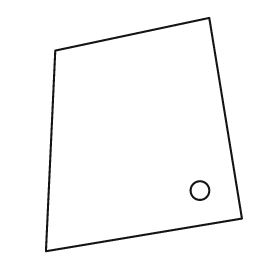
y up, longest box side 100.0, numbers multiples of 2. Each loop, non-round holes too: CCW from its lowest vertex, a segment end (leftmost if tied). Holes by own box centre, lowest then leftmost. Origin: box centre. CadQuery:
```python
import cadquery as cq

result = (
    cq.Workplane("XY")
    .moveTo(-42.0, -50.0)
    .lineTo(42.0, -36.0)
    .lineTo(28.0, 50.0)
    .lineTo(-38.0, 36.0)
    .close()
    .moveTo(24.0, -24.0)
    .circle(4.0)
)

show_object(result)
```